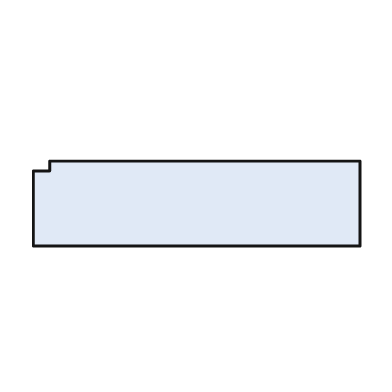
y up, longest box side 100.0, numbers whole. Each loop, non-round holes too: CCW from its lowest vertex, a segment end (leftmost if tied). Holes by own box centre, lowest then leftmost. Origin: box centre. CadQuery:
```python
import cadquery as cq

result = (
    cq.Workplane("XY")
    .moveTo(-50.0, -13.0)
    .lineTo(50.0, -13.0)
    .lineTo(50.0, 13.0)
    .lineTo(-45.0, 13.0)
    .lineTo(-45.0, 10.0)
    .lineTo(-50.0, 10.0)
    .close()
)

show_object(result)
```